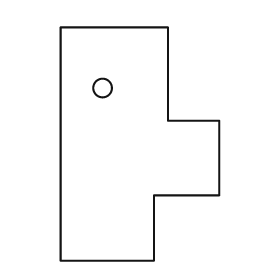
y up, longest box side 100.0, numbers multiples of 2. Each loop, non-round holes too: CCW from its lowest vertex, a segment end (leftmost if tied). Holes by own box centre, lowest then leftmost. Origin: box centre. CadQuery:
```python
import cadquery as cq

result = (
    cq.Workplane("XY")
    .moveTo(-34.0, -50.0)
    .lineTo(6.0, -50.0)
    .lineTo(6.0, -22.0)
    .lineTo(34.0, -22.0)
    .lineTo(34.0, 10.0)
    .lineTo(12.0, 10.0)
    .lineTo(12.0, 50.0)
    .lineTo(-34.0, 50.0)
    .close()
    .moveTo(-16.0, 24.0)
    .circle(4.0)
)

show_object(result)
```